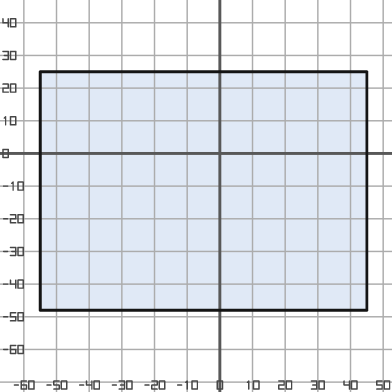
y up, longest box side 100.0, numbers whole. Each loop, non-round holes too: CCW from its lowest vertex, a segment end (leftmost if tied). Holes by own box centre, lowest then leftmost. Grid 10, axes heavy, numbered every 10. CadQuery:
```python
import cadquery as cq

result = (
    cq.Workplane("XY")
    .moveTo(-55.0, -48.0)
    .lineTo(45.0, -48.0)
    .lineTo(45.0, 25.0)
    .lineTo(-55.0, 25.0)
    .close()
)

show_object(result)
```